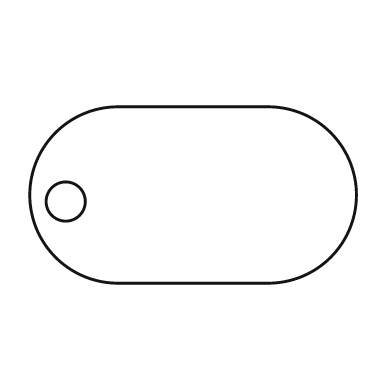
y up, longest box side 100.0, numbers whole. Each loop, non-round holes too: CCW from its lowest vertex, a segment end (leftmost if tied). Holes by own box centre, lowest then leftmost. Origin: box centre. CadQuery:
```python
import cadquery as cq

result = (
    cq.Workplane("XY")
    .moveTo(-23.0, -27.0)
    .lineTo(23.0, -27.0)
    .threePointArc((50.0, 0.0), (23.0, 27.0))
    .lineTo(-23.0, 27.0)
    .threePointArc((-50.0, 0.0), (-23.0, -27.0))
    .close()
    .moveTo(-39.0, -2.0)
    .circle(6.0)
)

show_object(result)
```